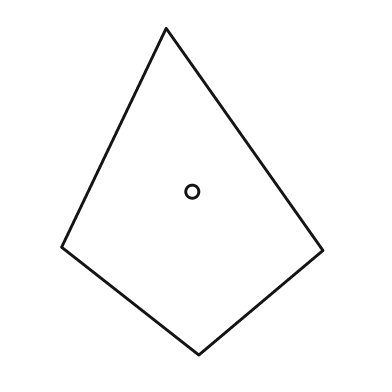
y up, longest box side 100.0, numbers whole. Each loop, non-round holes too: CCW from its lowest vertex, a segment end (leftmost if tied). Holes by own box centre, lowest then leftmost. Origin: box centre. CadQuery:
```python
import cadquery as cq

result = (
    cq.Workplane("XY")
    .moveTo(2.0, -50.0)
    .lineTo(40.0, -18.0)
    .lineTo(-8.0, 50.0)
    .lineTo(-40.0, -17.0)
    .close()
    .moveTo(0.0, 0.0)
    .circle(2.0)
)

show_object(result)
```